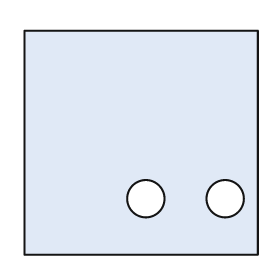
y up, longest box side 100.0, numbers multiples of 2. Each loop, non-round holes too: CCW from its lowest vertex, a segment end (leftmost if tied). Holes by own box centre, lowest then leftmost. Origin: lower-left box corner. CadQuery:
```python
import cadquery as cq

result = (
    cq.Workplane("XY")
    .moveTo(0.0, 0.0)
    .lineTo(100.0, 0.0)
    .lineTo(100.0, 96.0)
    .lineTo(0.0, 96.0)
    .close()
    .moveTo(52.0, 24.0)
    .circle(8.0)
    .moveTo(86.0, 24.0)
    .circle(8.0)
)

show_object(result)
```